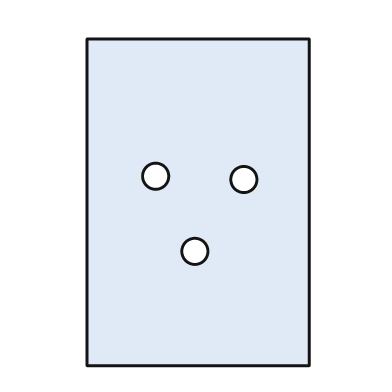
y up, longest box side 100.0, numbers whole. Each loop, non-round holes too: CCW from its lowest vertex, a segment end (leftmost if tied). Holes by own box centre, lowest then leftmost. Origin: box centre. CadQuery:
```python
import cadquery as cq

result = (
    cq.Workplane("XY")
    .moveTo(-34.0, -50.0)
    .lineTo(34.0, -50.0)
    .lineTo(34.0, 50.0)
    .lineTo(-34.0, 50.0)
    .close()
    .moveTo(-1.0, -15.0)
    .circle(4.0)
    .moveTo(14.0, 7.0)
    .circle(4.0)
    .moveTo(-13.0, 8.0)
    .circle(4.0)
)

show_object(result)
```